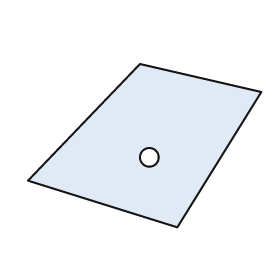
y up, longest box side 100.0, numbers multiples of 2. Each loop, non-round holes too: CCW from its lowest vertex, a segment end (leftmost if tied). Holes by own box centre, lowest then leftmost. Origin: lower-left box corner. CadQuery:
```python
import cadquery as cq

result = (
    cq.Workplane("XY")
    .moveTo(64.0, 0.0)
    .lineTo(100.0, 58.0)
    .lineTo(48.0, 70.0)
    .lineTo(0.0, 20.0)
    .close()
    .moveTo(52.0, 30.0)
    .circle(4.0)
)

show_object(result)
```